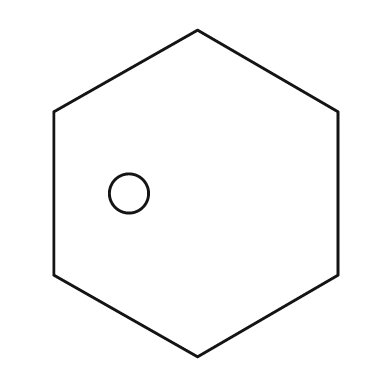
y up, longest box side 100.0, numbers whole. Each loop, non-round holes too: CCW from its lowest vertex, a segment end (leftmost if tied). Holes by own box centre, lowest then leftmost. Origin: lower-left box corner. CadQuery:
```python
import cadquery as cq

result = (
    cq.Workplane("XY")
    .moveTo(44.0, 0.0)
    .lineTo(87.0, 25.0)
    .lineTo(87.0, 75.0)
    .lineTo(44.0, 100.0)
    .lineTo(0.0, 75.0)
    .lineTo(0.0, 25.0)
    .close()
    .moveTo(23.0, 50.0)
    .circle(6.0)
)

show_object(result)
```